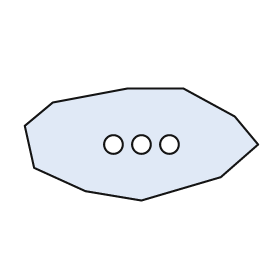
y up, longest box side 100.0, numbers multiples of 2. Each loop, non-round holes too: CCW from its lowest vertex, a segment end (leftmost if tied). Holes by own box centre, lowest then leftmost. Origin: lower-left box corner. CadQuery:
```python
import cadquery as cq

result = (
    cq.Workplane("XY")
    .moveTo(50.0, 0.0)
    .lineTo(84.0, 10.0)
    .lineTo(100.0, 24.0)
    .lineTo(90.0, 36.0)
    .lineTo(68.0, 48.0)
    .lineTo(44.0, 48.0)
    .lineTo(12.0, 42.0)
    .lineTo(0.0, 32.0)
    .lineTo(4.0, 14.0)
    .lineTo(26.0, 4.0)
    .close()
    .moveTo(38.0, 24.0)
    .circle(4.0)
    .moveTo(50.0, 24.0)
    .circle(4.0)
    .moveTo(62.0, 24.0)
    .circle(4.0)
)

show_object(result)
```